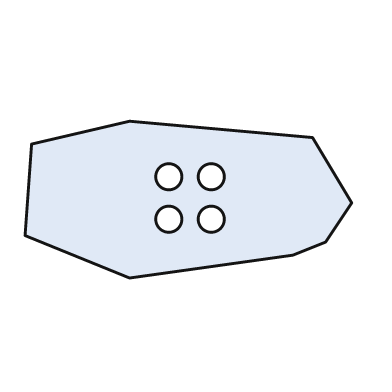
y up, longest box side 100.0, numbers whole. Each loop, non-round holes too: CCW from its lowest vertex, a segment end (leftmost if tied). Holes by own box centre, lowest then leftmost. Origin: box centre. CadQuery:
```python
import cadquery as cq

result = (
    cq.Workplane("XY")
    .moveTo(-18.0, -24.0)
    .lineTo(32.0, -17.0)
    .lineTo(42.0, -13.0)
    .lineTo(50.0, -1.0)
    .lineTo(38.0, 19.0)
    .lineTo(-18.0, 24.0)
    .lineTo(-48.0, 17.0)
    .lineTo(-50.0, -11.0)
    .close()
    .moveTo(-6.0, -6.0)
    .circle(4.0)
    .moveTo(7.0, -6.0)
    .circle(4.0)
    .moveTo(-6.0, 7.0)
    .circle(4.0)
    .moveTo(7.0, 7.0)
    .circle(4.0)
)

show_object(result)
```